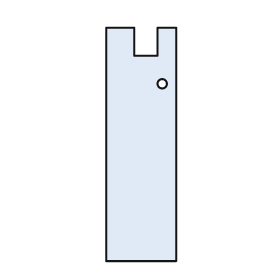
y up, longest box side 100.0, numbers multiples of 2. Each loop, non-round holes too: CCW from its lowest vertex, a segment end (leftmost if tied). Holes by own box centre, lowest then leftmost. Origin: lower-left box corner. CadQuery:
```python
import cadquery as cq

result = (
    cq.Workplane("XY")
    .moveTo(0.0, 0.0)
    .lineTo(30.0, 0.0)
    .lineTo(30.0, 100.0)
    .lineTo(22.0, 100.0)
    .lineTo(22.0, 88.0)
    .lineTo(12.0, 88.0)
    .lineTo(12.0, 100.0)
    .lineTo(0.0, 100.0)
    .close()
    .moveTo(24.0, 76.0)
    .circle(2.0)
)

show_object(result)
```